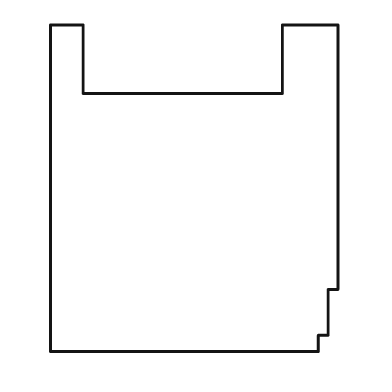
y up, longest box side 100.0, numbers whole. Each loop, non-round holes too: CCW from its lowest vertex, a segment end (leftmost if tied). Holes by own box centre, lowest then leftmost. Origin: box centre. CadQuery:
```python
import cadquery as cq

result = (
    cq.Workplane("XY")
    .moveTo(-44.0, -50.0)
    .lineTo(38.0, -50.0)
    .lineTo(38.0, -45.0)
    .lineTo(41.0, -45.0)
    .lineTo(41.0, -31.0)
    .lineTo(44.0, -31.0)
    .lineTo(44.0, 50.0)
    .lineTo(27.0, 50.0)
    .lineTo(27.0, 29.0)
    .lineTo(-34.0, 29.0)
    .lineTo(-34.0, 50.0)
    .lineTo(-44.0, 50.0)
    .close()
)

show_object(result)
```